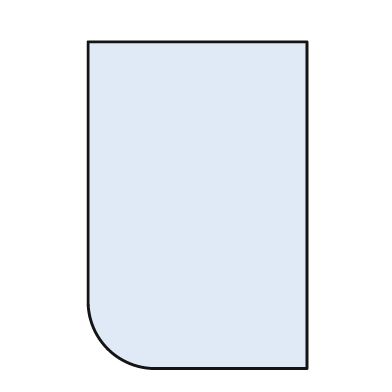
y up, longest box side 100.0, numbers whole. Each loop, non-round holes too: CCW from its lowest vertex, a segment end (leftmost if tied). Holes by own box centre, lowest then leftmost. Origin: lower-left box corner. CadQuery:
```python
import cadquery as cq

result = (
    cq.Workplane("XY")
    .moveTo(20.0, 0.0)
    .lineTo(67.0, 0.0)
    .lineTo(67.0, 100.0)
    .lineTo(0.0, 100.0)
    .lineTo(0.0, 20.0)
    .threePointArc((6.0, 6.0), (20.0, 0.0))
    .close()
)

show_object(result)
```